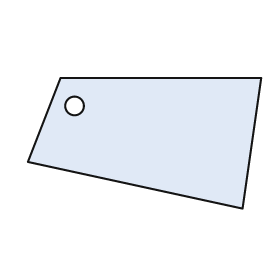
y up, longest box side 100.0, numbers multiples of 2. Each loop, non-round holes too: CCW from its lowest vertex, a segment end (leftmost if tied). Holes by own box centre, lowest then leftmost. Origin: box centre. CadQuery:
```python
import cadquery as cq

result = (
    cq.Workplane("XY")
    .moveTo(42.0, -28.0)
    .lineTo(50.0, 28.0)
    .lineTo(-36.0, 28.0)
    .lineTo(-50.0, -8.0)
    .close()
    .moveTo(-30.0, 16.0)
    .circle(4.0)
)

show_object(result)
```